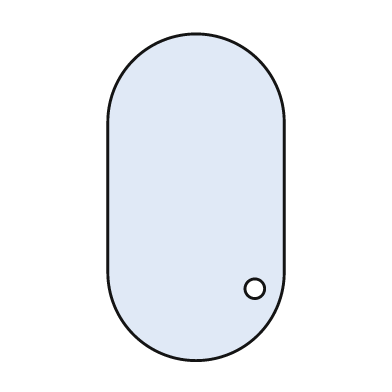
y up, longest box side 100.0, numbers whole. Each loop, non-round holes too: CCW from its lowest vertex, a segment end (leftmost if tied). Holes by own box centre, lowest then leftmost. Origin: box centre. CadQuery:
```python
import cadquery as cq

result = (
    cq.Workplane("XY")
    .moveTo(-27.0, -23.0)
    .threePointArc((0.0, -50.0), (27.0, -23.0))
    .lineTo(27.0, 23.0)
    .threePointArc((0.0, 50.0), (-27.0, 23.0))
    .close()
    .moveTo(18.0, -28.0)
    .circle(3.0)
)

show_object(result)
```